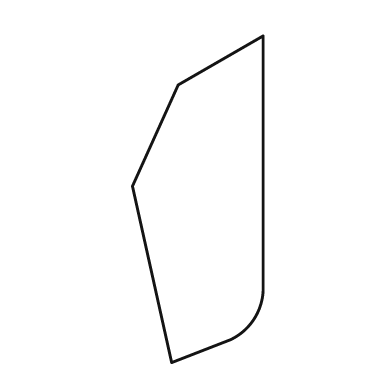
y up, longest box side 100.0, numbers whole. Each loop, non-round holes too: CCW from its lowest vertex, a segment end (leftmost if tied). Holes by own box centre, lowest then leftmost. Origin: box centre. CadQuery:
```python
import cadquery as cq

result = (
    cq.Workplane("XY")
    .moveTo(-8.0, -50.0)
    .lineTo(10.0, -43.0)
    .threePointArc((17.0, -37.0), (20.0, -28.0))
    .lineTo(20.0, 50.0)
    .lineTo(-6.0, 35.0)
    .lineTo(-20.0, 4.0)
    .close()
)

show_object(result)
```